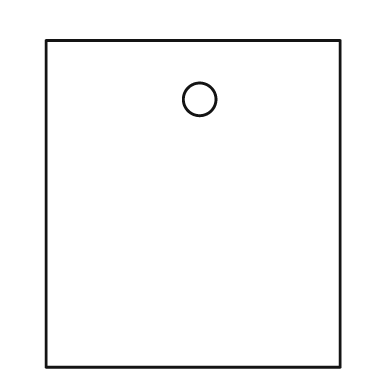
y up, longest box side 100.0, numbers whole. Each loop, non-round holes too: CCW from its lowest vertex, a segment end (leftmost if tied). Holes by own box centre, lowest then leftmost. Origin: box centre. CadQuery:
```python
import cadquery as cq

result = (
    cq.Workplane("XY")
    .moveTo(-45.0, -50.0)
    .lineTo(45.0, -50.0)
    .lineTo(45.0, 50.0)
    .lineTo(-45.0, 50.0)
    .close()
    .moveTo(2.0, 32.0)
    .circle(5.0)
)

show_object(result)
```